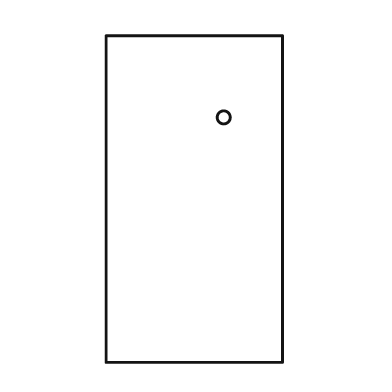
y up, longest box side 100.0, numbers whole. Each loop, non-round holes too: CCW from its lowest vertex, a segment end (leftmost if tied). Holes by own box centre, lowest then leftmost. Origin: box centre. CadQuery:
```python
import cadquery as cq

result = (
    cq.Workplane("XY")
    .moveTo(-27.0, -50.0)
    .lineTo(27.0, -50.0)
    .lineTo(27.0, 50.0)
    .lineTo(-27.0, 50.0)
    .close()
    .moveTo(9.0, 25.0)
    .circle(2.0)
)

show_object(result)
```